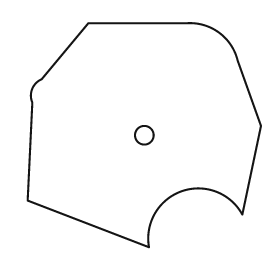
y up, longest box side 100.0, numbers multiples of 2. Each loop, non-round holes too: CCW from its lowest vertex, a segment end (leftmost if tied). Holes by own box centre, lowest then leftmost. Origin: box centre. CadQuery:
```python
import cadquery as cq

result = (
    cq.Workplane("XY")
    .moveTo(2.0, -48.0)
    .threePointArc((16.0, -24.0), (42.0, -34.0))
    .lineTo(50.0, 4.0)
    .lineTo(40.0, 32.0)
    .threePointArc((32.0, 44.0), (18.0, 48.0))
    .lineTo(-24.0, 48.0)
    .lineTo(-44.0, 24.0)
    .threePointArc((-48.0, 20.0), (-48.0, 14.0))
    .lineTo(-50.0, -28.0)
    .close()
    .moveTo(0.0, 0.0)
    .circle(4.0)
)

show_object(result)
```